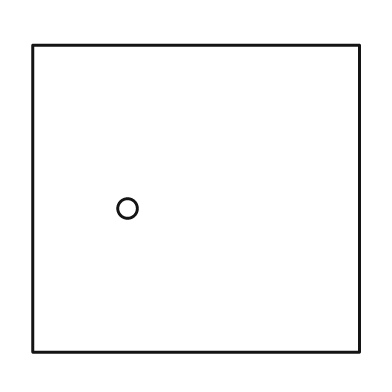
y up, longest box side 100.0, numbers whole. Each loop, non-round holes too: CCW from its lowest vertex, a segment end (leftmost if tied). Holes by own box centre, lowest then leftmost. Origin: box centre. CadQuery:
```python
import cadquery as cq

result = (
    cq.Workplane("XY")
    .moveTo(-50.0, -47.0)
    .lineTo(50.0, -47.0)
    .lineTo(50.0, 47.0)
    .lineTo(-50.0, 47.0)
    .close()
    .moveTo(-21.0, -3.0)
    .circle(3.0)
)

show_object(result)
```